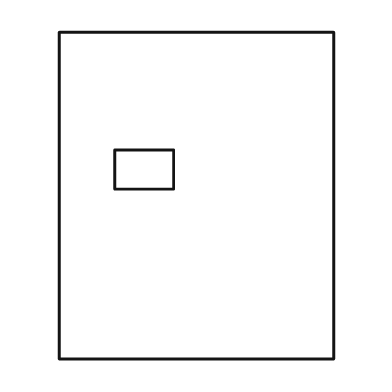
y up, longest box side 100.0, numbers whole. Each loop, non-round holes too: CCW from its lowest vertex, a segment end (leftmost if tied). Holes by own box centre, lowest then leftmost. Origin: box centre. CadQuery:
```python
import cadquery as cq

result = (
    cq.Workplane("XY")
    .moveTo(-42.0, -50.0)
    .lineTo(42.0, -50.0)
    .lineTo(42.0, 50.0)
    .lineTo(-42.0, 50.0)
    .close()
    .moveTo(-25.0, 2.0)
    .lineTo(-7.0, 2.0)
    .lineTo(-7.0, 14.0)
    .lineTo(-25.0, 14.0)
    .close()
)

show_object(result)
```